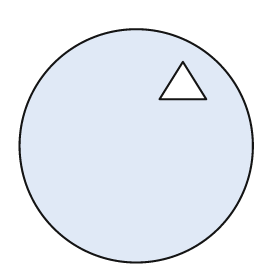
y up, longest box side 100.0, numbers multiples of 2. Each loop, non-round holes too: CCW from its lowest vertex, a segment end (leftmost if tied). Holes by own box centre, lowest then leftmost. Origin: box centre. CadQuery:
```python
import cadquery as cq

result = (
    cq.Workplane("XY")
    .moveTo(0.0, 0.0)
    .circle(50.0)
    .moveTo(10.0, 20.0)
    .lineTo(30.0, 20.0)
    .lineTo(20.0, 36.0)
    .close()
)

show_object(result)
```